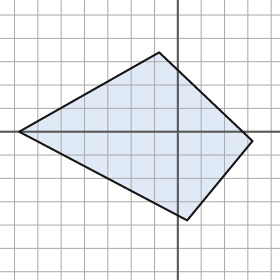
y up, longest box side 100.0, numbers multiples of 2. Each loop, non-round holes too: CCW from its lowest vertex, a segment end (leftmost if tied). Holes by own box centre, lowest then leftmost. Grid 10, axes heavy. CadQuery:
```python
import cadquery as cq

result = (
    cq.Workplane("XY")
    .moveTo(4.0, -38.0)
    .lineTo(32.0, -4.0)
    .lineTo(-8.0, 34.0)
    .lineTo(-68.0, 0.0)
    .close()
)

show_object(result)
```